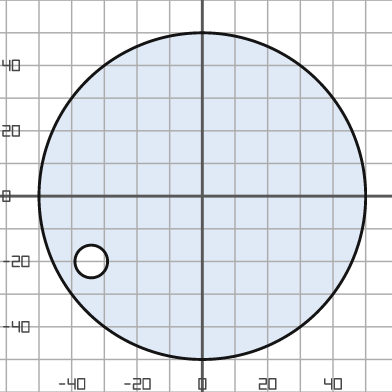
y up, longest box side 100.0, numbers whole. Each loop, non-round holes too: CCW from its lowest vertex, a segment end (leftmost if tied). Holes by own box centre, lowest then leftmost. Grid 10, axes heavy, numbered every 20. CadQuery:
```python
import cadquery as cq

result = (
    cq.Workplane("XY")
    .moveTo(0.0, 0.0)
    .circle(50.0)
    .moveTo(-34.0, -20.0)
    .circle(5.0)
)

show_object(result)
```